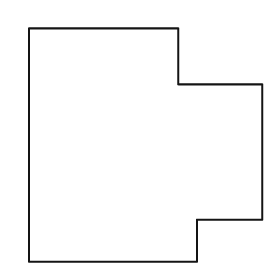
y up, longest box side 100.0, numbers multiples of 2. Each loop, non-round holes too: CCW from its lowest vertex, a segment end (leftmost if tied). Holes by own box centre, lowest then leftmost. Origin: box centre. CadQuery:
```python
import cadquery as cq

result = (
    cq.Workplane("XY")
    .moveTo(-50.0, -50.0)
    .lineTo(22.0, -50.0)
    .lineTo(22.0, -32.0)
    .lineTo(50.0, -32.0)
    .lineTo(50.0, 26.0)
    .lineTo(14.0, 26.0)
    .lineTo(14.0, 50.0)
    .lineTo(-50.0, 50.0)
    .close()
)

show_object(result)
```